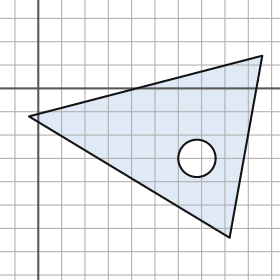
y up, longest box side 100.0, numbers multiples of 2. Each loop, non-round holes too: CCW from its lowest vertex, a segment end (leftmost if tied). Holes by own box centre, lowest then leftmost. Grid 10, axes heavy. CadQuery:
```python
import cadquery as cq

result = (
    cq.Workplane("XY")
    .moveTo(82.0, -64.0)
    .lineTo(96.0, 14.0)
    .lineTo(-4.0, -12.0)
    .close()
    .moveTo(68.0, -30.0)
    .circle(8.0)
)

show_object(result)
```